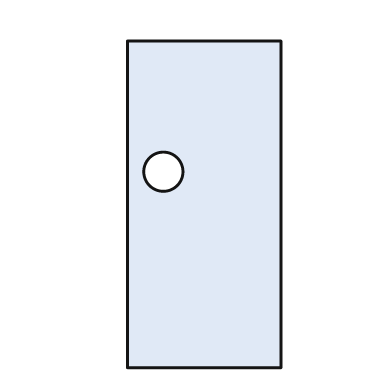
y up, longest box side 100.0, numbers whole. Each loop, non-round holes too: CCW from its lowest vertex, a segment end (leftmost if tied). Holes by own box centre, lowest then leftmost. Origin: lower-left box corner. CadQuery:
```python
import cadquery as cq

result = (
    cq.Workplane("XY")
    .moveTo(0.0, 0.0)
    .lineTo(47.0, 0.0)
    .lineTo(47.0, 100.0)
    .lineTo(0.0, 100.0)
    .close()
    .moveTo(11.0, 60.0)
    .circle(6.0)
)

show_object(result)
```